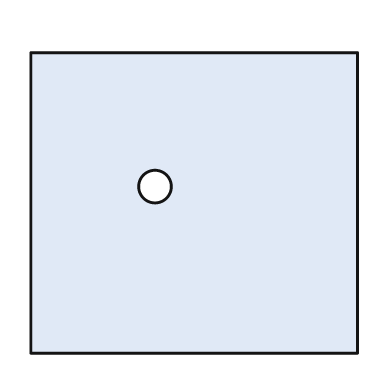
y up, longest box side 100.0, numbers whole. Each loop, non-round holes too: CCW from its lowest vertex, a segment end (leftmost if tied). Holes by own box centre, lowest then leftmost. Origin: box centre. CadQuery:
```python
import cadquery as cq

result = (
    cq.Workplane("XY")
    .moveTo(-50.0, -46.0)
    .lineTo(50.0, -46.0)
    .lineTo(50.0, 46.0)
    .lineTo(-50.0, 46.0)
    .close()
    .moveTo(-12.0, 5.0)
    .circle(5.0)
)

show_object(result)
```